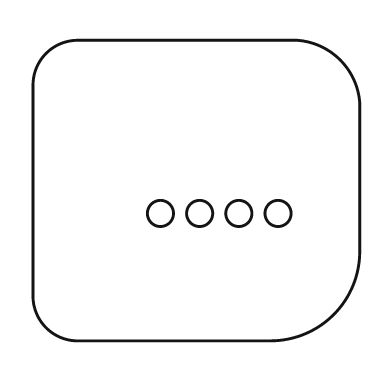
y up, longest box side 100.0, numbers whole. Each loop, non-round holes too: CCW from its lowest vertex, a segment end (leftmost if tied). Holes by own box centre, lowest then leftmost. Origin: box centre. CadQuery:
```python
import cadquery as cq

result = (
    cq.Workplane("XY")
    .moveTo(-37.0, -46.0)
    .lineTo(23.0, -46.0)
    .threePointArc((42.0, -38.0), (50.0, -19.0))
    .lineTo(50.0, 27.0)
    .threePointArc((44.0, 40.0), (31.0, 46.0))
    .lineTo(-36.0, 46.0)
    .threePointArc((-46.0, 42.0), (-50.0, 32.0))
    .lineTo(-50.0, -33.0)
    .threePointArc((-46.0, -42.0), (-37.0, -46.0))
    .close()
    .moveTo(-11.0, -7.0)
    .circle(4.0)
    .moveTo(1.0, -7.0)
    .circle(4.0)
    .moveTo(13.0, -7.0)
    .circle(4.0)
    .moveTo(25.0, -7.0)
    .circle(4.0)
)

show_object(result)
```